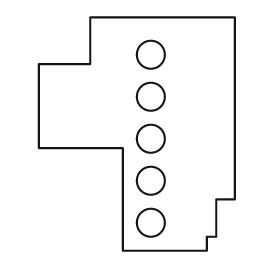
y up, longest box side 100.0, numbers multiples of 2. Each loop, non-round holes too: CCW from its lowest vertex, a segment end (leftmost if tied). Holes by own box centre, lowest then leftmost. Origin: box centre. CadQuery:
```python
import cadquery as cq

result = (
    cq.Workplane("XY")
    .moveTo(-6.0, -50.0)
    .lineTo(30.0, -50.0)
    .lineTo(30.0, -44.0)
    .lineTo(34.0, -44.0)
    .lineTo(34.0, -28.0)
    .lineTo(42.0, -28.0)
    .lineTo(42.0, 50.0)
    .lineTo(-20.0, 50.0)
    .lineTo(-20.0, 30.0)
    .lineTo(-42.0, 30.0)
    .lineTo(-42.0, -6.0)
    .lineTo(-6.0, -6.0)
    .close()
    .moveTo(6.0, -38.0)
    .circle(6.0)
    .moveTo(6.0, -20.0)
    .circle(6.0)
    .moveTo(6.0, -2.0)
    .circle(6.0)
    .moveTo(6.0, 16.0)
    .circle(6.0)
    .moveTo(6.0, 34.0)
    .circle(6.0)
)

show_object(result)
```